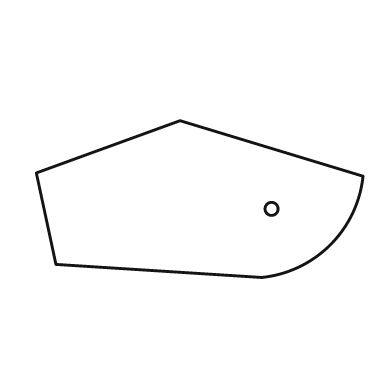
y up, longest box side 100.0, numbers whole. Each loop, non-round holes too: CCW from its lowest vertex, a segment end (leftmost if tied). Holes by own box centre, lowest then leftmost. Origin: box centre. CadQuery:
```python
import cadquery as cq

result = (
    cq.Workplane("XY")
    .moveTo(19.0, -24.0)
    .threePointArc((40.0, -14.0), (50.0, 7.0))
    .lineTo(-6.0, 24.0)
    .lineTo(-50.0, 8.0)
    .lineTo(-44.0, -20.0)
    .close()
    .moveTo(22.0, -3.0)
    .circle(2.0)
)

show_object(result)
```